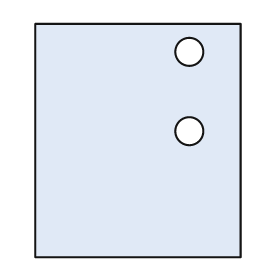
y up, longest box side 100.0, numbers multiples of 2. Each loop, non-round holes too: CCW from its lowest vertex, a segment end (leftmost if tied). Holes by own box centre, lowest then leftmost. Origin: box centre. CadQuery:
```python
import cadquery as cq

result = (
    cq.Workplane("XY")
    .moveTo(-44.0, -50.0)
    .lineTo(44.0, -50.0)
    .lineTo(44.0, 50.0)
    .lineTo(-44.0, 50.0)
    .close()
    .moveTo(22.0, 4.0)
    .circle(6.0)
    .moveTo(22.0, 38.0)
    .circle(6.0)
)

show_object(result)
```